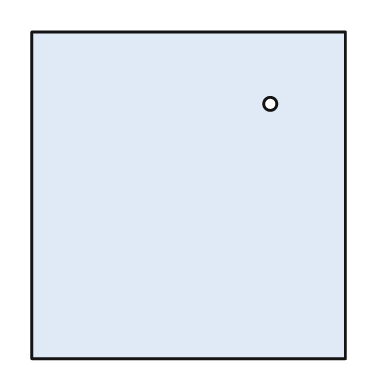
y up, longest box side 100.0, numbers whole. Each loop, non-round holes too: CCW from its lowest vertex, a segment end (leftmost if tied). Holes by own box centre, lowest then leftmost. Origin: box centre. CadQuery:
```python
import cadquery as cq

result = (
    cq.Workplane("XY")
    .moveTo(-48.0, -50.0)
    .lineTo(48.0, -50.0)
    .lineTo(48.0, 50.0)
    .lineTo(-48.0, 50.0)
    .close()
    .moveTo(25.0, 28.0)
    .circle(2.0)
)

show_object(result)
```